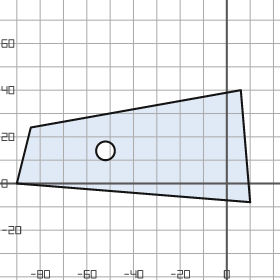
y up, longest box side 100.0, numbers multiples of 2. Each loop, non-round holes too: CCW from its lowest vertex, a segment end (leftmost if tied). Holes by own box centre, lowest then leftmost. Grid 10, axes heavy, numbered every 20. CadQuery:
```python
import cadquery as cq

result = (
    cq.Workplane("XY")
    .moveTo(10.0, -8.0)
    .lineTo(6.0, 40.0)
    .lineTo(-84.0, 24.0)
    .lineTo(-90.0, 0.0)
    .close()
    .moveTo(-52.0, 14.0)
    .circle(4.0)
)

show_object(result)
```